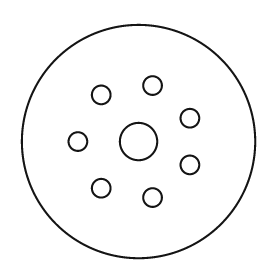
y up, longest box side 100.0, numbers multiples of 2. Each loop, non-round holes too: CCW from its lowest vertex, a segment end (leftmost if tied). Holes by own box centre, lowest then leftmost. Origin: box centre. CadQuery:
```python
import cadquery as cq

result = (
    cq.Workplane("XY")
    .moveTo(0.0, 0.0)
    .circle(50.0)
    .moveTo(6.0, -24.0)
    .circle(4.0)
    .moveTo(-16.0, -20.0)
    .circle(4.0)
    .moveTo(22.0, -10.0)
    .circle(4.0)
    .moveTo(-26.0, 0.0)
    .circle(4.0)
    .moveTo(0.0, 0.0)
    .circle(8.0)
    .moveTo(22.0, 10.0)
    .circle(4.0)
    .moveTo(-16.0, 20.0)
    .circle(4.0)
    .moveTo(6.0, 24.0)
    .circle(4.0)
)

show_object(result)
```